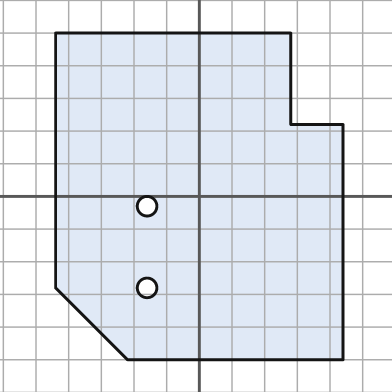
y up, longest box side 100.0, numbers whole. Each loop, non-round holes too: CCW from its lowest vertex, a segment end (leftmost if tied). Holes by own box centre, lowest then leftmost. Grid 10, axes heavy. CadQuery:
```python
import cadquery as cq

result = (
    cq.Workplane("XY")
    .moveTo(-22.0, -50.0)
    .lineTo(44.0, -50.0)
    .lineTo(44.0, 22.0)
    .lineTo(28.0, 22.0)
    .lineTo(28.0, 50.0)
    .lineTo(-44.0, 50.0)
    .lineTo(-44.0, -28.0)
    .close()
    .moveTo(-16.0, -28.0)
    .circle(3.0)
    .moveTo(-16.0, -3.0)
    .circle(3.0)
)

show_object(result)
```